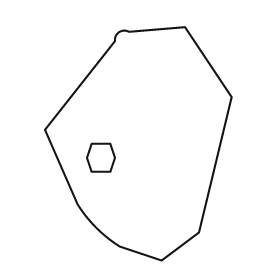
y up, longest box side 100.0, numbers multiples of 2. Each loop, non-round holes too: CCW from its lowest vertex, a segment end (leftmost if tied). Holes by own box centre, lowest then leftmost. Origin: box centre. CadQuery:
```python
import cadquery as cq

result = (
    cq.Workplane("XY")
    .moveTo(10.0, -50.0)
    .lineTo(26.0, -38.0)
    .lineTo(40.0, 20.0)
    .lineTo(20.0, 50.0)
    .lineTo(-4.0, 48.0)
    .threePointArc((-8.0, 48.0), (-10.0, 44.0))
    .lineTo(-40.0, 6.0)
    .lineTo(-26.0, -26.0)
    .threePointArc((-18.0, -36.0), (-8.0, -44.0))
    .close()
    .moveTo(-20.0, -12.0)
    .lineTo(-12.0, -12.0)
    .lineTo(-10.0, -6.0)
    .lineTo(-12.0, 0.0)
    .lineTo(-20.0, 0.0)
    .lineTo(-22.0, -6.0)
    .close()
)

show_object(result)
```